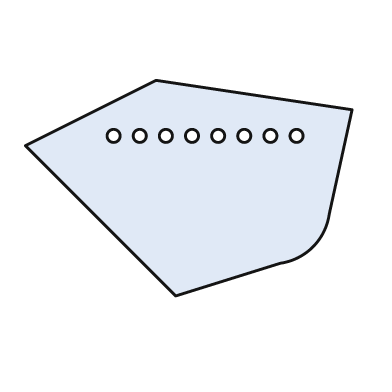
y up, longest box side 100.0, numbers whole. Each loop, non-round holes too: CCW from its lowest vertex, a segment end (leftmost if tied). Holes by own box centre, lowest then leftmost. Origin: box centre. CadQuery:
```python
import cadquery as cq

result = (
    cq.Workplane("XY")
    .moveTo(-4.0, -33.0)
    .lineTo(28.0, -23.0)
    .threePointArc((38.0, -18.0), (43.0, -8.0))
    .lineTo(50.0, 24.0)
    .lineTo(-10.0, 33.0)
    .lineTo(-50.0, 13.0)
    .close()
    .moveTo(-23.0, 16.0)
    .circle(2.0)
    .moveTo(-15.0, 16.0)
    .circle(2.0)
    .moveTo(-7.0, 16.0)
    .circle(2.0)
    .moveTo(1.0, 16.0)
    .circle(2.0)
    .moveTo(9.0, 16.0)
    .circle(2.0)
    .moveTo(17.0, 16.0)
    .circle(2.0)
    .moveTo(25.0, 16.0)
    .circle(2.0)
    .moveTo(33.0, 16.0)
    .circle(2.0)
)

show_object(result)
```